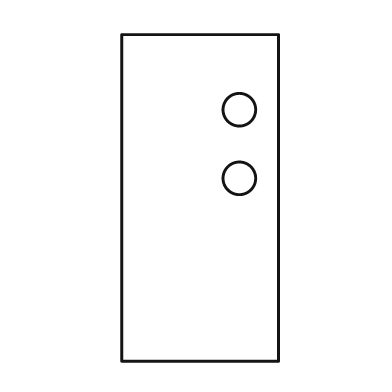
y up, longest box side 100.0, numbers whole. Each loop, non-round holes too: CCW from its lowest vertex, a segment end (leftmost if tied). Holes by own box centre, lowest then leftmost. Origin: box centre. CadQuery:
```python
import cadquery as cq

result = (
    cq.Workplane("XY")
    .moveTo(-24.0, -50.0)
    .lineTo(24.0, -50.0)
    .lineTo(24.0, 50.0)
    .lineTo(-24.0, 50.0)
    .close()
    .moveTo(12.0, 6.0)
    .circle(5.0)
    .moveTo(12.0, 27.0)
    .circle(5.0)
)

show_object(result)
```